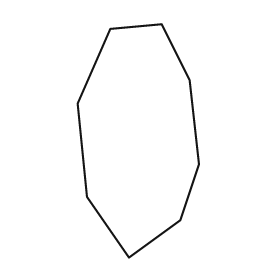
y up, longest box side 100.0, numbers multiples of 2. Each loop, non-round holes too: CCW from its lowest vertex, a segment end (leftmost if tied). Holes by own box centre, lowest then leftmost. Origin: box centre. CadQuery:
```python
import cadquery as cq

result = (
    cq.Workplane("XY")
    .moveTo(-4.0, -50.0)
    .lineTo(18.0, -34.0)
    .lineTo(26.0, -10.0)
    .lineTo(22.0, 26.0)
    .lineTo(10.0, 50.0)
    .lineTo(-12.0, 48.0)
    .lineTo(-26.0, 16.0)
    .lineTo(-22.0, -24.0)
    .close()
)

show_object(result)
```